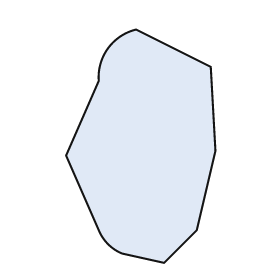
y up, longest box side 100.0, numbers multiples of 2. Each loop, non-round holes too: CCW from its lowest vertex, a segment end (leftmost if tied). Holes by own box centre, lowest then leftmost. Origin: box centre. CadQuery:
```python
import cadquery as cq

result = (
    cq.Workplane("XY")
    .moveTo(10.0, -50.0)
    .lineTo(24.0, -36.0)
    .lineTo(32.0, -2.0)
    .lineTo(30.0, 34.0)
    .lineTo(-2.0, 50.0)
    .threePointArc((-14.0, 42.0), (-18.0, 28.0))
    .lineTo(-32.0, -4.0)
    .lineTo(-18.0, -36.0)
    .threePointArc((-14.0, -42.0), (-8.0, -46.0))
    .close()
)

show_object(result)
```